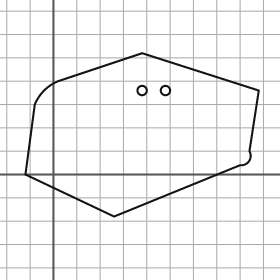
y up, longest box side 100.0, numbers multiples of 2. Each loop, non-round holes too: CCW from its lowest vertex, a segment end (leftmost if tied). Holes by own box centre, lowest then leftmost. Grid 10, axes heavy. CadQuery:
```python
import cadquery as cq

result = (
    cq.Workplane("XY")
    .moveTo(26.0, -18.0)
    .lineTo(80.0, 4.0)
    .threePointArc((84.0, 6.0), (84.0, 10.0))
    .lineTo(88.0, 36.0)
    .lineTo(38.0, 52.0)
    .lineTo(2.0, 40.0)
    .threePointArc((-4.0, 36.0), (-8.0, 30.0))
    .lineTo(-12.0, 0.0)
    .close()
    .moveTo(38.0, 36.0)
    .circle(2.0)
    .moveTo(48.0, 36.0)
    .circle(2.0)
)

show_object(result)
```